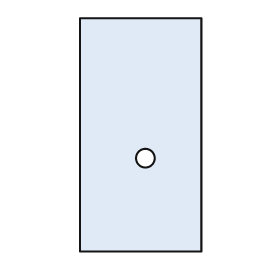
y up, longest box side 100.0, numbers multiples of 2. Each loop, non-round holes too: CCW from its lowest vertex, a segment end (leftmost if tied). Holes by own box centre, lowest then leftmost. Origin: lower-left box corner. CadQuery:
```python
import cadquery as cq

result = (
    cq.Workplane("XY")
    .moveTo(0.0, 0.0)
    .lineTo(52.0, 0.0)
    .lineTo(52.0, 100.0)
    .lineTo(0.0, 100.0)
    .close()
    .moveTo(28.0, 40.0)
    .circle(4.0)
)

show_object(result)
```